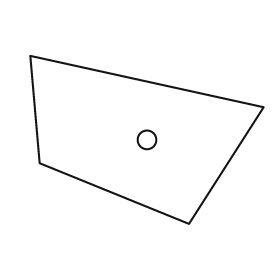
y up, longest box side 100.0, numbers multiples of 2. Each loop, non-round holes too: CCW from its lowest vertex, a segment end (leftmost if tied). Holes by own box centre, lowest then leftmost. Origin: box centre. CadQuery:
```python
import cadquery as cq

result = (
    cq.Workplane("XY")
    .moveTo(18.0, -36.0)
    .lineTo(50.0, 14.0)
    .lineTo(-50.0, 36.0)
    .lineTo(-46.0, -10.0)
    .close()
    .moveTo(0.0, 0.0)
    .circle(4.0)
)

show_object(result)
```